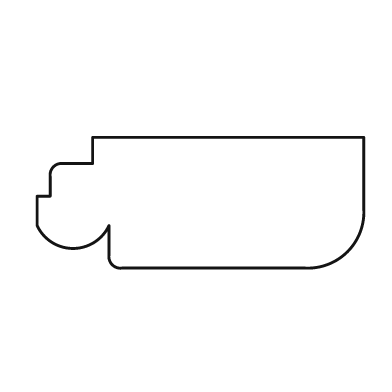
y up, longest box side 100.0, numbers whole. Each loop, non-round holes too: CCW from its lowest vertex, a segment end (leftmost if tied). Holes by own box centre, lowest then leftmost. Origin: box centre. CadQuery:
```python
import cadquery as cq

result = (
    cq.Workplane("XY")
    .moveTo(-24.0, -20.0)
    .lineTo(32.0, -20.0)
    .threePointArc((45.0, -15.0), (50.0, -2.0))
    .lineTo(50.0, 20.0)
    .lineTo(-33.0, 20.0)
    .lineTo(-33.0, 12.0)
    .lineTo(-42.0, 12.0)
    .threePointArc((-45.0, 11.0), (-46.0, 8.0))
    .lineTo(-46.0, 2.0)
    .lineTo(-50.0, 2.0)
    .lineTo(-50.0, -7.0)
    .threePointArc((-39.0, -14.0), (-28.0, -7.0))
    .lineTo(-28.0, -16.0)
    .threePointArc((-27.0, -19.0), (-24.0, -20.0))
    .close()
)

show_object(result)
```